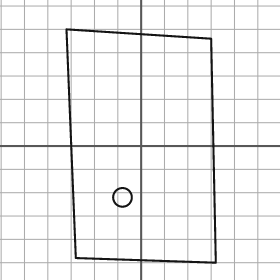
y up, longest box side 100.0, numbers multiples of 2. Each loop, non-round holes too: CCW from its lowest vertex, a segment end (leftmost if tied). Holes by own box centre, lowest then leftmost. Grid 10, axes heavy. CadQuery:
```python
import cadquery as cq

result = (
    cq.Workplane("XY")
    .moveTo(32.0, -50.0)
    .lineTo(30.0, 46.0)
    .lineTo(-32.0, 50.0)
    .lineTo(-28.0, -48.0)
    .close()
    .moveTo(-8.0, -22.0)
    .circle(4.0)
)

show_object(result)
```